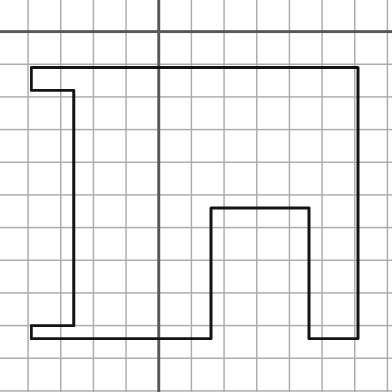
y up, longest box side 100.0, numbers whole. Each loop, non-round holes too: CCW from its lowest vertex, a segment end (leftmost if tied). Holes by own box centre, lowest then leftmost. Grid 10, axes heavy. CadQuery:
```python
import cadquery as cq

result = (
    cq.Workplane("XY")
    .moveTo(-39.0, -94.0)
    .lineTo(16.0, -94.0)
    .lineTo(16.0, -54.0)
    .lineTo(46.0, -54.0)
    .lineTo(46.0, -94.0)
    .lineTo(61.0, -94.0)
    .lineTo(61.0, -11.0)
    .lineTo(-39.0, -11.0)
    .lineTo(-39.0, -18.0)
    .lineTo(-26.0, -18.0)
    .lineTo(-26.0, -90.0)
    .lineTo(-39.0, -90.0)
    .close()
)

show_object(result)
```